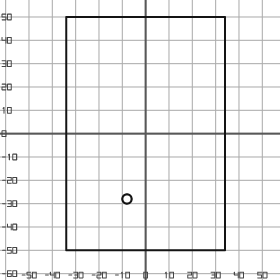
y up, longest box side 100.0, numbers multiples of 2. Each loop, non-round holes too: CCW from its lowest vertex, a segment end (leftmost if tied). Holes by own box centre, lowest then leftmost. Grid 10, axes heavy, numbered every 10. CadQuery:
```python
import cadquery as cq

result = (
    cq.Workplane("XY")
    .moveTo(-34.0, -50.0)
    .lineTo(34.0, -50.0)
    .lineTo(34.0, 50.0)
    .lineTo(-34.0, 50.0)
    .close()
    .moveTo(-8.0, -28.0)
    .circle(2.0)
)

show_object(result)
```